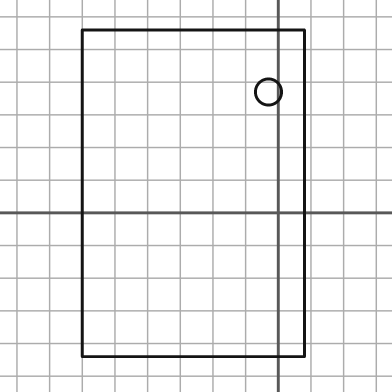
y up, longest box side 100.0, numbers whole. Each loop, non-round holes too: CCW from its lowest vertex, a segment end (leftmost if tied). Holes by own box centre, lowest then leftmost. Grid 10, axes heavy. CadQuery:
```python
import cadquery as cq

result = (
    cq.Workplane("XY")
    .moveTo(-60.0, -44.0)
    .lineTo(8.0, -44.0)
    .lineTo(8.0, 56.0)
    .lineTo(-60.0, 56.0)
    .close()
    .moveTo(-3.0, 37.0)
    .circle(4.0)
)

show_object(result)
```